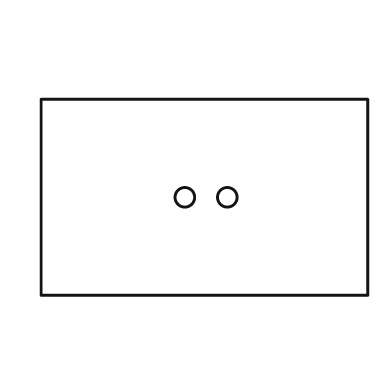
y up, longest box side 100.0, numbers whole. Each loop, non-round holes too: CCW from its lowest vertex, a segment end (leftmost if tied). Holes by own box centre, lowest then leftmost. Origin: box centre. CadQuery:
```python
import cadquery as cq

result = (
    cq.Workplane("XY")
    .moveTo(-50.0, -30.0)
    .lineTo(50.0, -30.0)
    .lineTo(50.0, 30.0)
    .lineTo(-50.0, 30.0)
    .close()
    .moveTo(-6.0, 0.0)
    .circle(3.0)
    .moveTo(7.0, 0.0)
    .circle(3.0)
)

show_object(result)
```